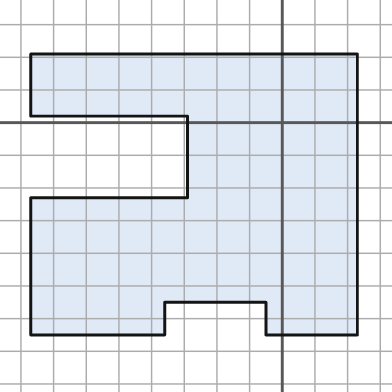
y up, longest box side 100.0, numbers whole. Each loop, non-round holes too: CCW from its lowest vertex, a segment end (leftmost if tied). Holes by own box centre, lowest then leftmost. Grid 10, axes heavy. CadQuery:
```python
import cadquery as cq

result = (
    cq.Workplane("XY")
    .moveTo(-77.0, -65.0)
    .lineTo(-36.0, -65.0)
    .lineTo(-36.0, -55.0)
    .lineTo(-5.0, -55.0)
    .lineTo(-5.0, -65.0)
    .lineTo(23.0, -65.0)
    .lineTo(23.0, 21.0)
    .lineTo(-77.0, 21.0)
    .lineTo(-77.0, 2.0)
    .lineTo(-29.0, 2.0)
    .lineTo(-29.0, -23.0)
    .lineTo(-77.0, -23.0)
    .close()
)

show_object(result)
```